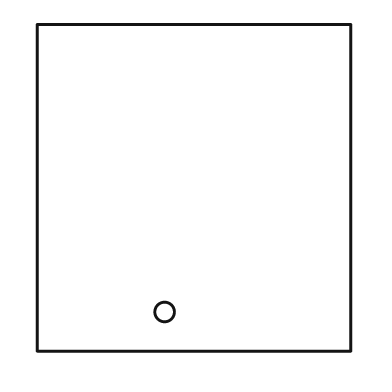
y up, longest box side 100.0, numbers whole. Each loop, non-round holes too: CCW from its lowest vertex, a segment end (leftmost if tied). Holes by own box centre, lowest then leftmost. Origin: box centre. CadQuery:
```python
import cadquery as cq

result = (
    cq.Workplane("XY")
    .moveTo(-48.0, -50.0)
    .lineTo(48.0, -50.0)
    .lineTo(48.0, 50.0)
    .lineTo(-48.0, 50.0)
    .close()
    .moveTo(-9.0, -38.0)
    .circle(3.0)
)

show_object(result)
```